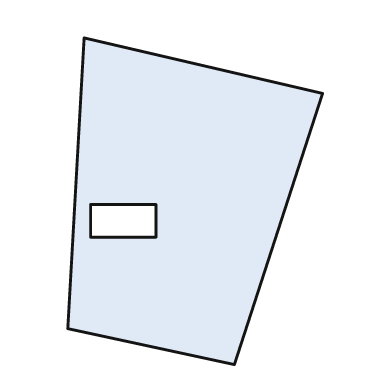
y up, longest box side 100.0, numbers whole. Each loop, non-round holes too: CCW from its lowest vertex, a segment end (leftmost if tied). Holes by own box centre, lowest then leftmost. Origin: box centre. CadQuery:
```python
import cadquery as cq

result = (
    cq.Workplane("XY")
    .moveTo(12.0, -50.0)
    .lineTo(39.0, 33.0)
    .lineTo(-34.0, 50.0)
    .lineTo(-39.0, -39.0)
    .close()
    .moveTo(-32.0, -11.0)
    .lineTo(-12.0, -11.0)
    .lineTo(-12.0, -1.0)
    .lineTo(-32.0, -1.0)
    .close()
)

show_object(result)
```